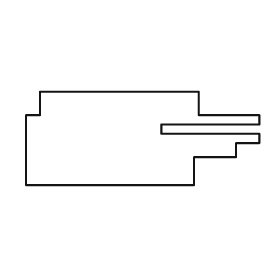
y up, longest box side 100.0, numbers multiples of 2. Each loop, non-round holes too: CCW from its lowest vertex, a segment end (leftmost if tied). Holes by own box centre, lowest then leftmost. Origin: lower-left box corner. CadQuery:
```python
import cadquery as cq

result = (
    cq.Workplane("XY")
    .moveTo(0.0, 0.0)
    .lineTo(72.0, 0.0)
    .lineTo(72.0, 12.0)
    .lineTo(90.0, 12.0)
    .lineTo(90.0, 18.0)
    .lineTo(100.0, 18.0)
    .lineTo(100.0, 22.0)
    .lineTo(58.0, 22.0)
    .lineTo(58.0, 26.0)
    .lineTo(100.0, 26.0)
    .lineTo(100.0, 30.0)
    .lineTo(74.0, 30.0)
    .lineTo(74.0, 40.0)
    .lineTo(6.0, 40.0)
    .lineTo(6.0, 30.0)
    .lineTo(0.0, 30.0)
    .close()
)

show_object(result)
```